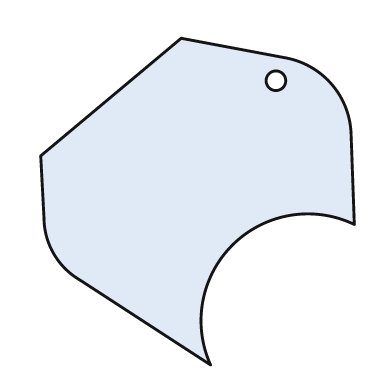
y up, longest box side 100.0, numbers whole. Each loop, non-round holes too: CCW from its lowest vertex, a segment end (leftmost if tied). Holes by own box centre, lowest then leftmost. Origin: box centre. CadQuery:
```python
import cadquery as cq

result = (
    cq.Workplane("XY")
    .moveTo(4.0, -50.0)
    .threePointArc((11.0, -13.0), (48.0, -7.0))
    .lineTo(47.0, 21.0)
    .threePointArc((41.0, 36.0), (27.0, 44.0))
    .lineTo(-5.0, 50.0)
    .lineTo(-48.0, 14.0)
    .lineTo(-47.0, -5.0)
    .threePointArc((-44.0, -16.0), (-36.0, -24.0))
    .close()
    .moveTo(24.0, 37.0)
    .circle(3.0)
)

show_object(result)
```